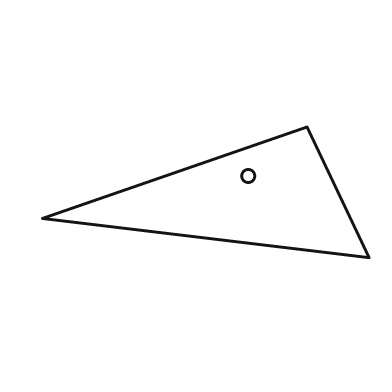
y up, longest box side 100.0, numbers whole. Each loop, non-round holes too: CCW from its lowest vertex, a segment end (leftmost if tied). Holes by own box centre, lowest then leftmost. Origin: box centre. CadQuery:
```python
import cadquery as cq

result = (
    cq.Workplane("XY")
    .moveTo(50.0, -20.0)
    .lineTo(31.0, 20.0)
    .lineTo(-50.0, -8.0)
    .close()
    .moveTo(13.0, 5.0)
    .circle(2.0)
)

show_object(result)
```